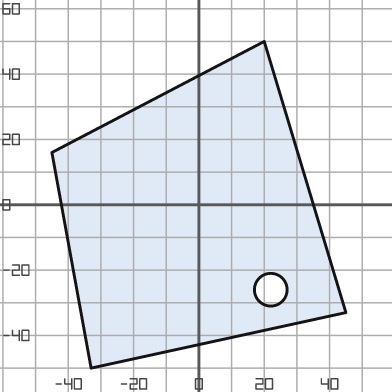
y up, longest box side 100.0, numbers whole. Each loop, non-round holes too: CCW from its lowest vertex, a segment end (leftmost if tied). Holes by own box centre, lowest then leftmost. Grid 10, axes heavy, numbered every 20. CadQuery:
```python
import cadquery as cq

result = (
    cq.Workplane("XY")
    .moveTo(-33.0, -50.0)
    .lineTo(45.0, -33.0)
    .lineTo(20.0, 50.0)
    .lineTo(-45.0, 16.0)
    .close()
    .moveTo(22.0, -26.0)
    .circle(5.0)
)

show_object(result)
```